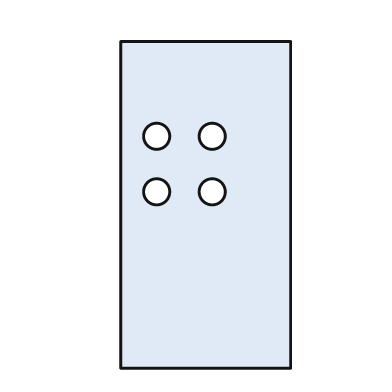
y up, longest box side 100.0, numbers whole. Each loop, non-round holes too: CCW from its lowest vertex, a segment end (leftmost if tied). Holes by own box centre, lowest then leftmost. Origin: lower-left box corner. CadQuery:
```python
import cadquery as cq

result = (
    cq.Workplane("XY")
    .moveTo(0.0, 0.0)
    .lineTo(52.0, 0.0)
    .lineTo(52.0, 100.0)
    .lineTo(0.0, 100.0)
    .close()
    .moveTo(11.0, 54.0)
    .circle(4.0)
    .moveTo(28.0, 54.0)
    .circle(4.0)
    .moveTo(11.0, 71.0)
    .circle(4.0)
    .moveTo(28.0, 71.0)
    .circle(4.0)
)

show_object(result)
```